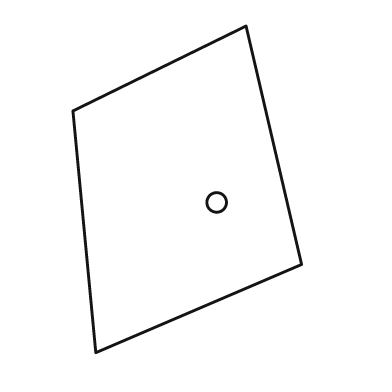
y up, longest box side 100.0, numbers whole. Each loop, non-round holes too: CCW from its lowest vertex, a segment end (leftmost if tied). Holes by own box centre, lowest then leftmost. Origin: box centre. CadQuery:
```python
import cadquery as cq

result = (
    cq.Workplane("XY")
    .moveTo(-28.0, -50.0)
    .lineTo(35.0, -23.0)
    .lineTo(18.0, 50.0)
    .lineTo(-35.0, 24.0)
    .close()
    .moveTo(9.0, -4.0)
    .circle(3.0)
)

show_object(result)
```